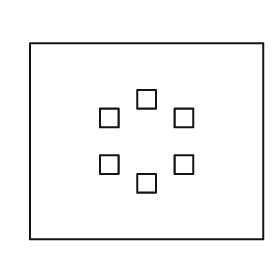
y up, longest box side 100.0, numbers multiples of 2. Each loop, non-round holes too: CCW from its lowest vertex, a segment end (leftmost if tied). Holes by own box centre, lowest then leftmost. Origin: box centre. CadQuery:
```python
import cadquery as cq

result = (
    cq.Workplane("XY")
    .moveTo(-50.0, -42.0)
    .lineTo(50.0, -42.0)
    .lineTo(50.0, 42.0)
    .lineTo(-50.0, 42.0)
    .close()
    .moveTo(-4.0, -22.0)
    .lineTo(4.0, -22.0)
    .lineTo(4.0, -14.0)
    .lineTo(-4.0, -14.0)
    .close()
    .moveTo(-20.0, -14.0)
    .lineTo(-12.0, -14.0)
    .lineTo(-12.0, -6.0)
    .lineTo(-20.0, -6.0)
    .close()
    .moveTo(12.0, -14.0)
    .lineTo(20.0, -14.0)
    .lineTo(20.0, -6.0)
    .lineTo(12.0, -6.0)
    .close()
    .moveTo(-20.0, 6.0)
    .lineTo(-12.0, 6.0)
    .lineTo(-12.0, 14.0)
    .lineTo(-20.0, 14.0)
    .close()
    .moveTo(12.0, 6.0)
    .lineTo(20.0, 6.0)
    .lineTo(20.0, 14.0)
    .lineTo(12.0, 14.0)
    .close()
    .moveTo(-4.0, 14.0)
    .lineTo(4.0, 14.0)
    .lineTo(4.0, 22.0)
    .lineTo(-4.0, 22.0)
    .close()
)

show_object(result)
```